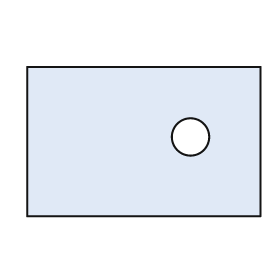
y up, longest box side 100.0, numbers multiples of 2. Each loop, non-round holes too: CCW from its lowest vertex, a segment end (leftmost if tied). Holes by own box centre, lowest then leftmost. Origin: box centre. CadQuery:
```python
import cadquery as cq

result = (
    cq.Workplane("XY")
    .moveTo(-50.0, -32.0)
    .lineTo(50.0, -32.0)
    .lineTo(50.0, 32.0)
    .lineTo(-50.0, 32.0)
    .close()
    .moveTo(20.0, 2.0)
    .circle(8.0)
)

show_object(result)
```